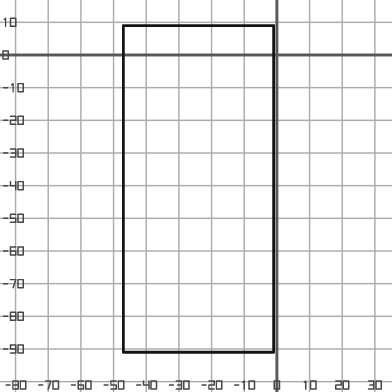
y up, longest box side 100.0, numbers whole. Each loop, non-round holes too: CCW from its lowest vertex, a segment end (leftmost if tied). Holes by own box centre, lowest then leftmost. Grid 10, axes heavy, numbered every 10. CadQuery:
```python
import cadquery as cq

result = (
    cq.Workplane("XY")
    .moveTo(-47.0, -91.0)
    .lineTo(-1.0, -91.0)
    .lineTo(-1.0, 9.0)
    .lineTo(-47.0, 9.0)
    .close()
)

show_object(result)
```